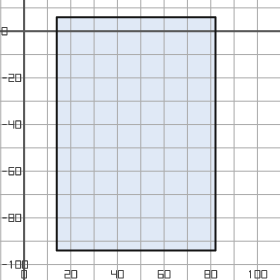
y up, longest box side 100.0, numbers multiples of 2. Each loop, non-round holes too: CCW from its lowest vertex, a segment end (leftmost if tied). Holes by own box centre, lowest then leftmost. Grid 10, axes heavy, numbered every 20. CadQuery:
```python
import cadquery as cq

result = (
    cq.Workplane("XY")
    .moveTo(14.0, -94.0)
    .lineTo(82.0, -94.0)
    .lineTo(82.0, 6.0)
    .lineTo(14.0, 6.0)
    .close()
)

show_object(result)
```